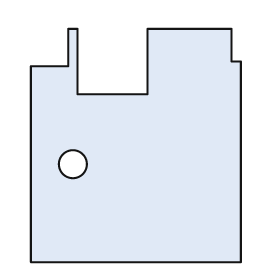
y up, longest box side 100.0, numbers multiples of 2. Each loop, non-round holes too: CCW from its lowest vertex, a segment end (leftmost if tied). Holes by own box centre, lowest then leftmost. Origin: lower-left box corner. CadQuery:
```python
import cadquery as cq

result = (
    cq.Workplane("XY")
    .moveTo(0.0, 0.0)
    .lineTo(90.0, 0.0)
    .lineTo(90.0, 86.0)
    .lineTo(86.0, 86.0)
    .lineTo(86.0, 100.0)
    .lineTo(50.0, 100.0)
    .lineTo(50.0, 72.0)
    .lineTo(20.0, 72.0)
    .lineTo(20.0, 100.0)
    .lineTo(16.0, 100.0)
    .lineTo(16.0, 84.0)
    .lineTo(0.0, 84.0)
    .close()
    .moveTo(18.0, 42.0)
    .circle(6.0)
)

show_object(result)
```